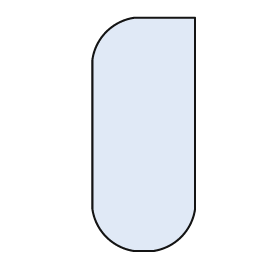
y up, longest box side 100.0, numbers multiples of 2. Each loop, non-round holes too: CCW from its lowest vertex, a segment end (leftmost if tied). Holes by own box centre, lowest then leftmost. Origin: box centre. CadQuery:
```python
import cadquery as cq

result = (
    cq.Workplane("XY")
    .moveTo(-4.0, -50.0)
    .lineTo(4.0, -50.0)
    .threePointArc((16.0, -44.0), (22.0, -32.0))
    .lineTo(22.0, 50.0)
    .lineTo(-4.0, 50.0)
    .threePointArc((-16.0, 44.0), (-22.0, 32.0))
    .lineTo(-22.0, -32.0)
    .threePointArc((-16.0, -44.0), (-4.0, -50.0))
    .close()
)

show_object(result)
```